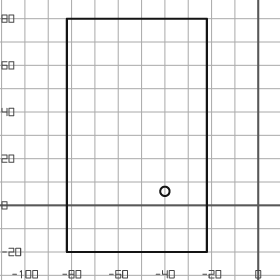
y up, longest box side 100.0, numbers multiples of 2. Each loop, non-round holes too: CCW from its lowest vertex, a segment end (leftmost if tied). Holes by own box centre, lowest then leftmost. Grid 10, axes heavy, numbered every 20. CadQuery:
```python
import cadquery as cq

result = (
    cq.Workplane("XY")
    .moveTo(-82.0, -20.0)
    .lineTo(-22.0, -20.0)
    .lineTo(-22.0, 80.0)
    .lineTo(-82.0, 80.0)
    .close()
    .moveTo(-40.0, 6.0)
    .circle(2.0)
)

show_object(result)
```